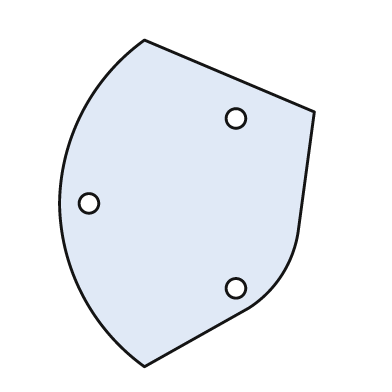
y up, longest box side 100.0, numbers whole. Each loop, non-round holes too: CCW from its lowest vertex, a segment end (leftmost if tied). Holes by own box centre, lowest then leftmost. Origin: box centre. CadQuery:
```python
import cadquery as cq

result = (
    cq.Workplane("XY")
    .moveTo(-13.0, -50.0)
    .lineTo(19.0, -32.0)
    .threePointArc((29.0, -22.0), (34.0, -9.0))
    .lineTo(39.0, 28.0)
    .lineTo(-13.0, 50.0)
    .threePointArc((-32.0, 28.0), (-39.0, 0.0))
    .threePointArc((-32.0, -28.0), (-13.0, -50.0))
    .close()
    .moveTo(15.0, -26.0)
    .circle(3.0)
    .moveTo(-30.0, 0.0)
    .circle(3.0)
    .moveTo(15.0, 26.0)
    .circle(3.0)
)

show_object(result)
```